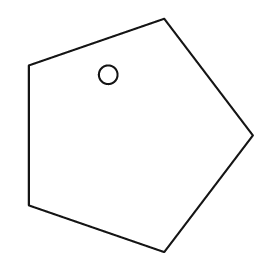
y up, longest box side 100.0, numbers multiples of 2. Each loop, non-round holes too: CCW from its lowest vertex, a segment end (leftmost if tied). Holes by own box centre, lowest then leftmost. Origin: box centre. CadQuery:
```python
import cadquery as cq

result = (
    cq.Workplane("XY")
    .moveTo(10.0, -50.0)
    .lineTo(48.0, 0.0)
    .lineTo(10.0, 50.0)
    .lineTo(-48.0, 30.0)
    .lineTo(-48.0, -30.0)
    .close()
    .moveTo(-14.0, 26.0)
    .circle(4.0)
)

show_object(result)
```